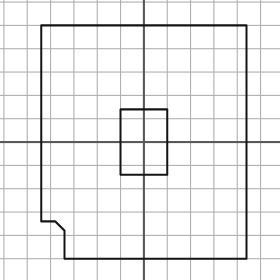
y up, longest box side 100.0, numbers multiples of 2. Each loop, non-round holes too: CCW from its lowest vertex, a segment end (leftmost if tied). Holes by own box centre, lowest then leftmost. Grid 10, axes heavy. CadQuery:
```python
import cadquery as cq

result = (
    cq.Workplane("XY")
    .moveTo(-34.0, -50.0)
    .lineTo(44.0, -50.0)
    .lineTo(44.0, 50.0)
    .lineTo(-44.0, 50.0)
    .lineTo(-44.0, -34.0)
    .lineTo(-38.0, -34.0)
    .lineTo(-34.0, -38.0)
    .close()
    .moveTo(-10.0, -14.0)
    .lineTo(10.0, -14.0)
    .lineTo(10.0, 14.0)
    .lineTo(-10.0, 14.0)
    .close()
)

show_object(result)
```